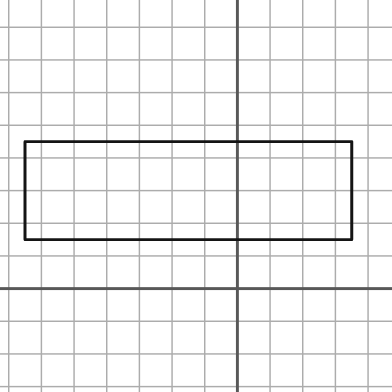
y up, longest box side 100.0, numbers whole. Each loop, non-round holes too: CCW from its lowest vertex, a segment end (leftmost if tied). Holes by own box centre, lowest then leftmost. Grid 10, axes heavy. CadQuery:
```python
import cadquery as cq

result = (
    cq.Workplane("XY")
    .moveTo(-65.0, 15.0)
    .lineTo(35.0, 15.0)
    .lineTo(35.0, 45.0)
    .lineTo(-65.0, 45.0)
    .close()
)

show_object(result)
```